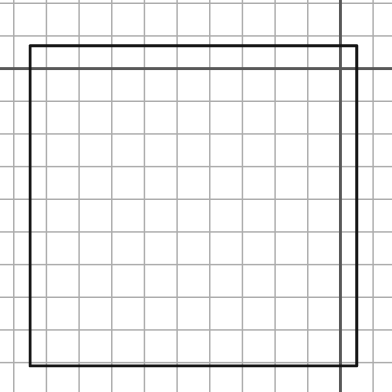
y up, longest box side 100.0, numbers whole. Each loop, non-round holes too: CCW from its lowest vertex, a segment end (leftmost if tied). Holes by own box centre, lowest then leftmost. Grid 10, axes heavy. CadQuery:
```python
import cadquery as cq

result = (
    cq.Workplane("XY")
    .moveTo(-95.0, -91.0)
    .lineTo(5.0, -91.0)
    .lineTo(5.0, 7.0)
    .lineTo(-95.0, 7.0)
    .close()
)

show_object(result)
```